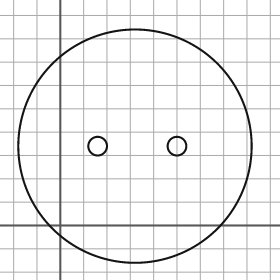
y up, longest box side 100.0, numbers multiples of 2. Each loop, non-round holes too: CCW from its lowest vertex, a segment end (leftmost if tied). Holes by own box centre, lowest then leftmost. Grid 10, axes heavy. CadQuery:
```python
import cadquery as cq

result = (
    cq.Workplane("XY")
    .moveTo(32.0, 34.0)
    .circle(50.0)
    .moveTo(16.0, 34.0)
    .circle(4.0)
    .moveTo(50.0, 34.0)
    .circle(4.0)
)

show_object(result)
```